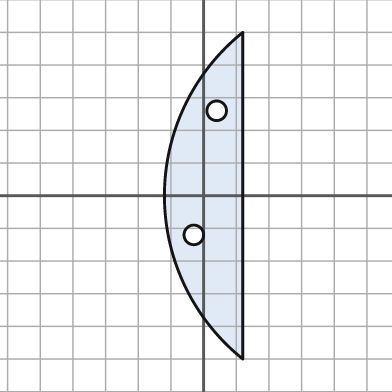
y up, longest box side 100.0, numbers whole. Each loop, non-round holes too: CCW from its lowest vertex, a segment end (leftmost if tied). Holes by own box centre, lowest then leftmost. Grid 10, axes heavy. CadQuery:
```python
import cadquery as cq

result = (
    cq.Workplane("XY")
    .moveTo(12.0, -50.0)
    .lineTo(12.0, 50.0)
    .threePointArc((-12.0, 0.0), (12.0, -50.0))
    .close()
    .moveTo(-3.0, -12.0)
    .circle(3.0)
    .moveTo(4.0, 26.0)
    .circle(3.0)
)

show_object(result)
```